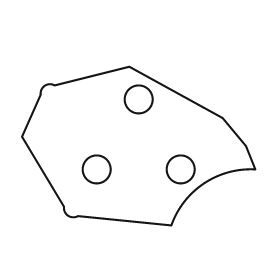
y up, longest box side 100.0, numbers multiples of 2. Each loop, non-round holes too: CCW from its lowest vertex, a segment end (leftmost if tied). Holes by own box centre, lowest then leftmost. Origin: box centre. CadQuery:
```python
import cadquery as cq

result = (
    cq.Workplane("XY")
    .moveTo(14.0, -34.0)
    .threePointArc((28.0, -16.0), (50.0, -10.0))
    .lineTo(46.0, 0.0)
    .lineTo(36.0, 12.0)
    .lineTo(-4.0, 34.0)
    .lineTo(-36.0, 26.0)
    .threePointArc((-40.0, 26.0), (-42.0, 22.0))
    .lineTo(-50.0, 4.0)
    .lineTo(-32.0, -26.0)
    .threePointArc((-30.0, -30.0), (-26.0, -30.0))
    .close()
    .moveTo(-18.0, -10.0)
    .circle(6.0)
    .moveTo(18.0, -10.0)
    .circle(6.0)
    .moveTo(0.0, 20.0)
    .circle(6.0)
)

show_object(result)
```